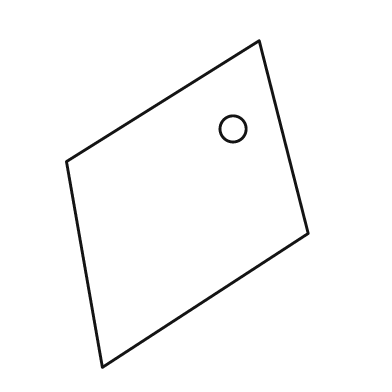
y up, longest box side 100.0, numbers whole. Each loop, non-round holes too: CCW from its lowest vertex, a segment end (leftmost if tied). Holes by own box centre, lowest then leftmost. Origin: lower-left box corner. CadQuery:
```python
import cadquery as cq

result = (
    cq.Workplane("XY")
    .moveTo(11.0, 0.0)
    .lineTo(74.0, 41.0)
    .lineTo(59.0, 100.0)
    .lineTo(0.0, 63.0)
    .close()
    .moveTo(51.0, 73.0)
    .circle(4.0)
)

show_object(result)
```